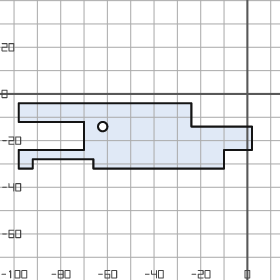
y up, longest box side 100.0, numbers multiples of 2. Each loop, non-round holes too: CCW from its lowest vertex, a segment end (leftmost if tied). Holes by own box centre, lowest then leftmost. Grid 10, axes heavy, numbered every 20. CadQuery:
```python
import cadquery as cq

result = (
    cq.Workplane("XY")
    .moveTo(-98.0, -32.0)
    .lineTo(-92.0, -32.0)
    .lineTo(-92.0, -28.0)
    .lineTo(-66.0, -28.0)
    .lineTo(-66.0, -32.0)
    .lineTo(-10.0, -32.0)
    .lineTo(-10.0, -24.0)
    .lineTo(2.0, -24.0)
    .lineTo(2.0, -14.0)
    .lineTo(-24.0, -14.0)
    .lineTo(-24.0, -4.0)
    .lineTo(-98.0, -4.0)
    .lineTo(-98.0, -12.0)
    .lineTo(-70.0, -12.0)
    .lineTo(-70.0, -24.0)
    .lineTo(-98.0, -24.0)
    .close()
    .moveTo(-62.0, -14.0)
    .circle(2.0)
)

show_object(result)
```